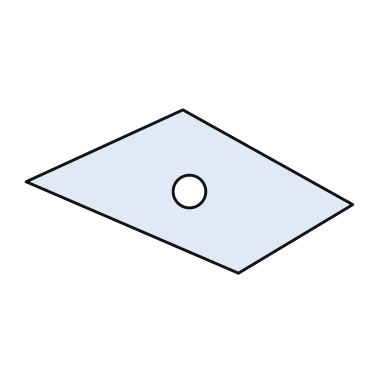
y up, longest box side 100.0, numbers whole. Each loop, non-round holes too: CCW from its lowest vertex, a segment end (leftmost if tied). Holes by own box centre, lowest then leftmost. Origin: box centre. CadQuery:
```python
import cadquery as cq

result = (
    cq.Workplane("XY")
    .moveTo(15.0, -25.0)
    .lineTo(50.0, -4.0)
    .lineTo(-2.0, 25.0)
    .lineTo(-50.0, 3.0)
    .close()
    .moveTo(0.0, 0.0)
    .circle(5.0)
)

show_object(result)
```